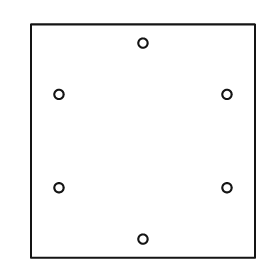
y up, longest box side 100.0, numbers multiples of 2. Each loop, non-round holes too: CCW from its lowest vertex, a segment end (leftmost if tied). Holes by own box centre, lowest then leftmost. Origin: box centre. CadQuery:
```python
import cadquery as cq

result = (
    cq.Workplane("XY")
    .moveTo(-48.0, -50.0)
    .lineTo(48.0, -50.0)
    .lineTo(48.0, 50.0)
    .lineTo(-48.0, 50.0)
    .close()
    .moveTo(0.0, -42.0)
    .circle(2.0)
    .moveTo(-36.0, -20.0)
    .circle(2.0)
    .moveTo(36.0, -20.0)
    .circle(2.0)
    .moveTo(-36.0, 20.0)
    .circle(2.0)
    .moveTo(36.0, 20.0)
    .circle(2.0)
    .moveTo(0.0, 42.0)
    .circle(2.0)
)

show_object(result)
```